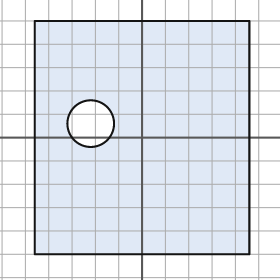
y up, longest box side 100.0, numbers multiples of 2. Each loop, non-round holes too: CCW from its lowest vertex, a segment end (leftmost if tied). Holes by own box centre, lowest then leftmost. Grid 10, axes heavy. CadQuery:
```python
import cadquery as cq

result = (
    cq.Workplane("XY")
    .moveTo(-46.0, -50.0)
    .lineTo(46.0, -50.0)
    .lineTo(46.0, 50.0)
    .lineTo(-46.0, 50.0)
    .close()
    .moveTo(-22.0, 6.0)
    .circle(10.0)
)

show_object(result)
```